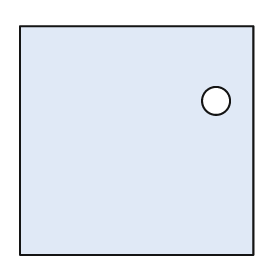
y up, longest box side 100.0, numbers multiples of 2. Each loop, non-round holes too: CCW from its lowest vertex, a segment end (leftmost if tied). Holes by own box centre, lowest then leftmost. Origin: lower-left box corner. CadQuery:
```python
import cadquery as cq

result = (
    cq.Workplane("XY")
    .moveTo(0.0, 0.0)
    .lineTo(100.0, 0.0)
    .lineTo(100.0, 98.0)
    .lineTo(0.0, 98.0)
    .close()
    .moveTo(84.0, 66.0)
    .circle(6.0)
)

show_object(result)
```